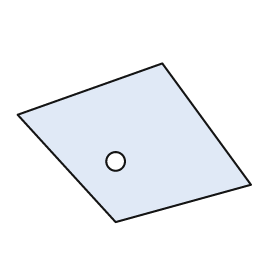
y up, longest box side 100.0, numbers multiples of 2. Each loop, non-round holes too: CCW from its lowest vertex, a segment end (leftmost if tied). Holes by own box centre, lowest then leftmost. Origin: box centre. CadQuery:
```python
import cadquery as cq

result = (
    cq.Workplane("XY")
    .moveTo(-8.0, -34.0)
    .lineTo(50.0, -18.0)
    .lineTo(12.0, 34.0)
    .lineTo(-50.0, 12.0)
    .close()
    .moveTo(-8.0, -8.0)
    .circle(4.0)
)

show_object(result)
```